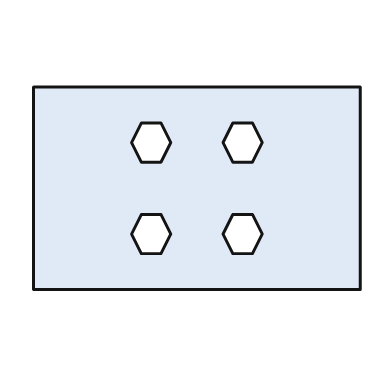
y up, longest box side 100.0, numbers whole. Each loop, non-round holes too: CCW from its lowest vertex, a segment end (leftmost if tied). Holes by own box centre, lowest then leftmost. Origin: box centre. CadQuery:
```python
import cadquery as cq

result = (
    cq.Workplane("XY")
    .moveTo(-50.0, -31.0)
    .lineTo(50.0, -31.0)
    .lineTo(50.0, 31.0)
    .lineTo(-50.0, 31.0)
    .close()
    .moveTo(-17.0, -20.0)
    .lineTo(-11.0, -20.0)
    .lineTo(-8.0, -14.0)
    .lineTo(-11.0, -8.0)
    .lineTo(-17.0, -8.0)
    .lineTo(-20.0, -14.0)
    .close()
    .moveTo(11.0, -20.0)
    .lineTo(17.0, -20.0)
    .lineTo(20.0, -14.0)
    .lineTo(17.0, -8.0)
    .lineTo(11.0, -8.0)
    .lineTo(8.0, -14.0)
    .close()
    .moveTo(-17.0, 8.0)
    .lineTo(-11.0, 8.0)
    .lineTo(-8.0, 14.0)
    .lineTo(-11.0, 20.0)
    .lineTo(-17.0, 20.0)
    .lineTo(-20.0, 14.0)
    .close()
    .moveTo(11.0, 8.0)
    .lineTo(17.0, 8.0)
    .lineTo(20.0, 14.0)
    .lineTo(17.0, 20.0)
    .lineTo(11.0, 20.0)
    .lineTo(8.0, 14.0)
    .close()
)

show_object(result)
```